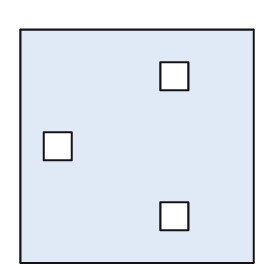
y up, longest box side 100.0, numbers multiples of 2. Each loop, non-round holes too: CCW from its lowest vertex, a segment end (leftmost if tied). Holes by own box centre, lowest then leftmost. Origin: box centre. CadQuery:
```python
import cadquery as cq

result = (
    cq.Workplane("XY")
    .moveTo(-50.0, -50.0)
    .lineTo(50.0, -50.0)
    .lineTo(50.0, 50.0)
    .lineTo(-50.0, 50.0)
    .close()
    .moveTo(10.0, -36.0)
    .lineTo(22.0, -36.0)
    .lineTo(22.0, -24.0)
    .lineTo(10.0, -24.0)
    .close()
    .moveTo(-40.0, -6.0)
    .lineTo(-28.0, -6.0)
    .lineTo(-28.0, 6.0)
    .lineTo(-40.0, 6.0)
    .close()
    .moveTo(10.0, 24.0)
    .lineTo(22.0, 24.0)
    .lineTo(22.0, 36.0)
    .lineTo(10.0, 36.0)
    .close()
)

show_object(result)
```